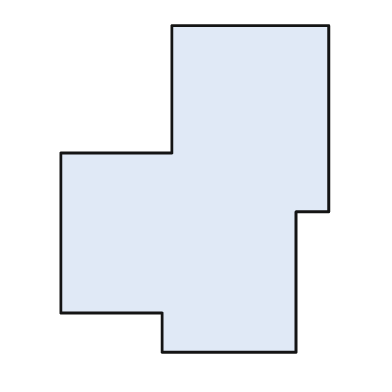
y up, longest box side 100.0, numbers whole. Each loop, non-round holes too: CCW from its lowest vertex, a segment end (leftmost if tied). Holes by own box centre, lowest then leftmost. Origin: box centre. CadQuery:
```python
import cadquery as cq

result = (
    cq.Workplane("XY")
    .moveTo(-10.0, -50.0)
    .lineTo(31.0, -50.0)
    .lineTo(31.0, -7.0)
    .lineTo(41.0, -7.0)
    .lineTo(41.0, 50.0)
    .lineTo(-7.0, 50.0)
    .lineTo(-7.0, 11.0)
    .lineTo(-41.0, 11.0)
    .lineTo(-41.0, -38.0)
    .lineTo(-10.0, -38.0)
    .close()
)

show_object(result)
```